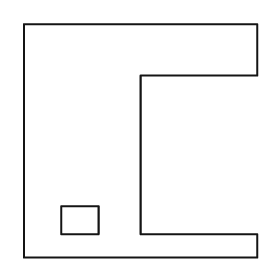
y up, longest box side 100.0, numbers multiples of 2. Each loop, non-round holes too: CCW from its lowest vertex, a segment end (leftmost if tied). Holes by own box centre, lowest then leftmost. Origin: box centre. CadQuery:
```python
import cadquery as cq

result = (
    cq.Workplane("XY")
    .moveTo(-50.0, -50.0)
    .lineTo(50.0, -50.0)
    .lineTo(50.0, -40.0)
    .lineTo(0.0, -40.0)
    .lineTo(0.0, 28.0)
    .lineTo(50.0, 28.0)
    .lineTo(50.0, 50.0)
    .lineTo(-50.0, 50.0)
    .close()
    .moveTo(-34.0, -40.0)
    .lineTo(-18.0, -40.0)
    .lineTo(-18.0, -28.0)
    .lineTo(-34.0, -28.0)
    .close()
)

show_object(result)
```